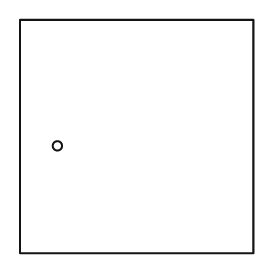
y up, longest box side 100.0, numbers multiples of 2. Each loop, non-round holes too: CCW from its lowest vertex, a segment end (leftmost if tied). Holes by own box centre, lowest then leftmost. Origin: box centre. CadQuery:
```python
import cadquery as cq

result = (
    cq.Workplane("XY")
    .moveTo(-50.0, -50.0)
    .lineTo(50.0, -50.0)
    .lineTo(50.0, 50.0)
    .lineTo(-50.0, 50.0)
    .close()
    .moveTo(-34.0, -4.0)
    .circle(2.0)
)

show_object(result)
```